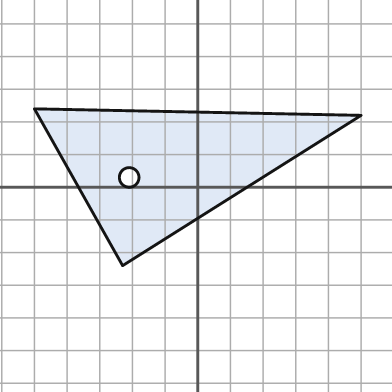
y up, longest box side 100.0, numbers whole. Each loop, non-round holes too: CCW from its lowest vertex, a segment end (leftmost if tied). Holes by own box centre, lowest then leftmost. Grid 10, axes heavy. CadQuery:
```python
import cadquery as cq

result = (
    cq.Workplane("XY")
    .moveTo(-23.0, -24.0)
    .lineTo(50.0, 22.0)
    .lineTo(-50.0, 24.0)
    .close()
    .moveTo(-21.0, 3.0)
    .circle(3.0)
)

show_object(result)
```